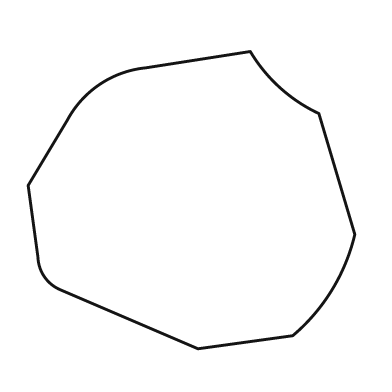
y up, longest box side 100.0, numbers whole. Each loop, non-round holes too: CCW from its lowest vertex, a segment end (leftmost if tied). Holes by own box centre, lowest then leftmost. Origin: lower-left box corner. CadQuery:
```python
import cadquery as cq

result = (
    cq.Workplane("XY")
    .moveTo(52.0, 0.0)
    .lineTo(81.0, 4.0)
    .threePointArc((93.0, 18.0), (100.0, 35.0))
    .lineTo(89.0, 72.0)
    .threePointArc((77.0, 80.0), (68.0, 91.0))
    .lineTo(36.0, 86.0)
    .threePointArc((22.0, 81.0), (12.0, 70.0))
    .lineTo(0.0, 50.0)
    .lineTo(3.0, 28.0)
    .threePointArc((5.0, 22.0), (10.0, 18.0))
    .close()
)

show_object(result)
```